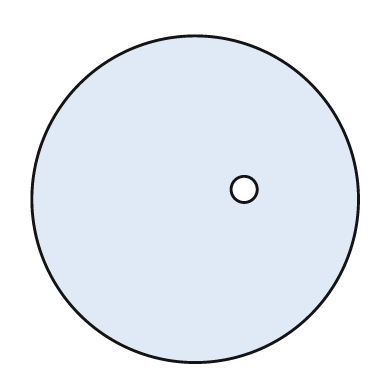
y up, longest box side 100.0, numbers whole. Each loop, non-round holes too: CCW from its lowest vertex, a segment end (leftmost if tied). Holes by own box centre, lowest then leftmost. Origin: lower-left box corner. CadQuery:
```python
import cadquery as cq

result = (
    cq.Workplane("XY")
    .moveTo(50.0, 50.0)
    .circle(50.0)
    .moveTo(65.0, 53.0)
    .circle(4.0)
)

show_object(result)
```